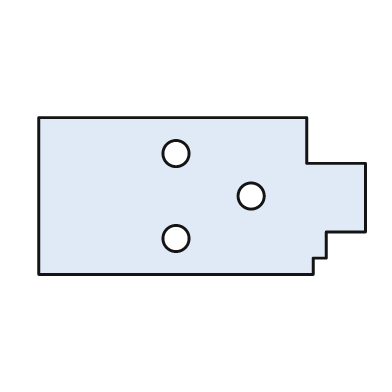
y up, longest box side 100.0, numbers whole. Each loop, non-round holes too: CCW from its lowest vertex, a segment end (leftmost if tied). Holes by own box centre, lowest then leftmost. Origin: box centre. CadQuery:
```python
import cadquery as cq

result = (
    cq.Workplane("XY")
    .moveTo(-50.0, -24.0)
    .lineTo(34.0, -24.0)
    .lineTo(34.0, -19.0)
    .lineTo(38.0, -19.0)
    .lineTo(38.0, -11.0)
    .lineTo(50.0, -11.0)
    .lineTo(50.0, 10.0)
    .lineTo(32.0, 10.0)
    .lineTo(32.0, 24.0)
    .lineTo(-50.0, 24.0)
    .close()
    .moveTo(-8.0, -13.0)
    .circle(4.0)
    .moveTo(15.0, 0.0)
    .circle(4.0)
    .moveTo(-8.0, 13.0)
    .circle(4.0)
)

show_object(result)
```